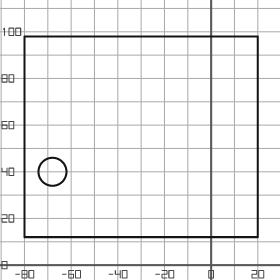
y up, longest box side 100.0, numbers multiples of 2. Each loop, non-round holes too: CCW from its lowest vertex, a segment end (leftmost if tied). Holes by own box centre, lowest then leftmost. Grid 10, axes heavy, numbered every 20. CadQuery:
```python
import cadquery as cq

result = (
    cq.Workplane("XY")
    .moveTo(-80.0, 12.0)
    .lineTo(20.0, 12.0)
    .lineTo(20.0, 98.0)
    .lineTo(-80.0, 98.0)
    .close()
    .moveTo(-68.0, 40.0)
    .circle(6.0)
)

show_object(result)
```